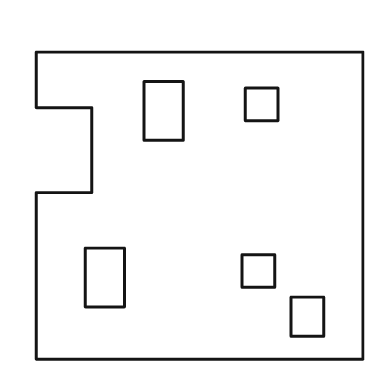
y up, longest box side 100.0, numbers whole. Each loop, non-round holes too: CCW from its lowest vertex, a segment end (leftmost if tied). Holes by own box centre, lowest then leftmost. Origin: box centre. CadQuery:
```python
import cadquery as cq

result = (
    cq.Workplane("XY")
    .moveTo(-50.0, -47.0)
    .lineTo(50.0, -47.0)
    .lineTo(50.0, 47.0)
    .lineTo(-50.0, 47.0)
    .lineTo(-50.0, 30.0)
    .lineTo(-33.0, 30.0)
    .lineTo(-33.0, 4.0)
    .lineTo(-50.0, 4.0)
    .close()
    .moveTo(28.0, -40.0)
    .lineTo(38.0, -40.0)
    .lineTo(38.0, -28.0)
    .lineTo(28.0, -28.0)
    .close()
    .moveTo(-35.0, -31.0)
    .lineTo(-23.0, -31.0)
    .lineTo(-23.0, -13.0)
    .lineTo(-35.0, -13.0)
    .close()
    .moveTo(13.0, -25.0)
    .lineTo(23.0, -25.0)
    .lineTo(23.0, -15.0)
    .lineTo(13.0, -15.0)
    .close()
    .moveTo(-17.0, 20.0)
    .lineTo(-5.0, 20.0)
    .lineTo(-5.0, 38.0)
    .lineTo(-17.0, 38.0)
    .close()
    .moveTo(14.0, 26.0)
    .lineTo(24.0, 26.0)
    .lineTo(24.0, 36.0)
    .lineTo(14.0, 36.0)
    .close()
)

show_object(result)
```